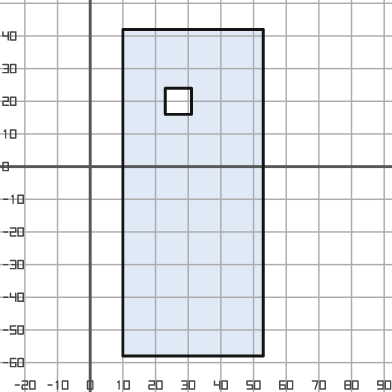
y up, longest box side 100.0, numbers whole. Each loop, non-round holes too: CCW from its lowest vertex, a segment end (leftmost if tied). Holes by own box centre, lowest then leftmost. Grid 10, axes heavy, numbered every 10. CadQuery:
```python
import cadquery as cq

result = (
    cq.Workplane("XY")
    .moveTo(10.0, -58.0)
    .lineTo(53.0, -58.0)
    .lineTo(53.0, 42.0)
    .lineTo(10.0, 42.0)
    .close()
    .moveTo(23.0, 16.0)
    .lineTo(31.0, 16.0)
    .lineTo(31.0, 24.0)
    .lineTo(23.0, 24.0)
    .close()
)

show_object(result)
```